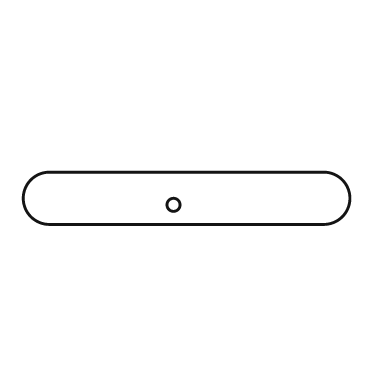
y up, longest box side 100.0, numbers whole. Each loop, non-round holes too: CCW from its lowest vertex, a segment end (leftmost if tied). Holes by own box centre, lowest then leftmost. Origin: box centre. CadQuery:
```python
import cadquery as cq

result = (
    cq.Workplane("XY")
    .moveTo(-42.0, -8.0)
    .lineTo(42.0, -8.0)
    .threePointArc((50.0, 0.0), (42.0, 8.0))
    .lineTo(-42.0, 8.0)
    .threePointArc((-50.0, 0.0), (-42.0, -8.0))
    .close()
    .moveTo(-4.0, -2.0)
    .circle(2.0)
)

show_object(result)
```